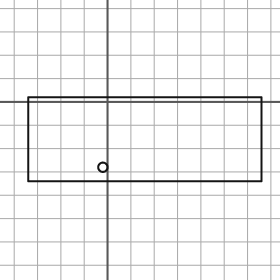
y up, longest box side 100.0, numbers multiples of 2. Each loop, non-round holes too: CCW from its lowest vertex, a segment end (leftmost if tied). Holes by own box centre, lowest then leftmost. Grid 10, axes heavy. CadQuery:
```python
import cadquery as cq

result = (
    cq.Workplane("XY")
    .moveTo(-34.0, -34.0)
    .lineTo(66.0, -34.0)
    .lineTo(66.0, 2.0)
    .lineTo(-34.0, 2.0)
    .close()
    .moveTo(-2.0, -28.0)
    .circle(2.0)
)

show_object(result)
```